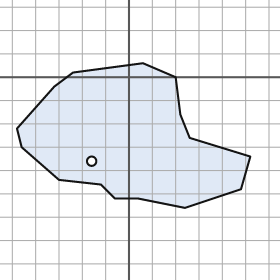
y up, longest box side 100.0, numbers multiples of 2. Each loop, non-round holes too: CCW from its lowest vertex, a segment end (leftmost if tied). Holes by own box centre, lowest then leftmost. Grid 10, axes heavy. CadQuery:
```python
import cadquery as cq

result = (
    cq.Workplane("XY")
    .moveTo(24.0, -56.0)
    .lineTo(48.0, -48.0)
    .lineTo(52.0, -34.0)
    .lineTo(26.0, -26.0)
    .lineTo(22.0, -16.0)
    .lineTo(20.0, 0.0)
    .lineTo(6.0, 6.0)
    .lineTo(-24.0, 2.0)
    .lineTo(-32.0, -4.0)
    .lineTo(-48.0, -22.0)
    .lineTo(-46.0, -30.0)
    .lineTo(-30.0, -44.0)
    .lineTo(-12.0, -46.0)
    .lineTo(-6.0, -52.0)
    .lineTo(4.0, -52.0)
    .close()
    .moveTo(-16.0, -36.0)
    .circle(2.0)
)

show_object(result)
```